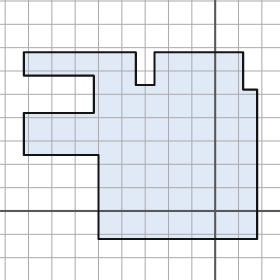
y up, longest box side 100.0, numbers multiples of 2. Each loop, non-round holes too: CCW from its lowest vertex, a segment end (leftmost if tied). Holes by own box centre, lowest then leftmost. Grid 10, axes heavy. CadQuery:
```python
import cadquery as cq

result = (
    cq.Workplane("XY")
    .moveTo(-50.0, -12.0)
    .lineTo(18.0, -12.0)
    .lineTo(18.0, 52.0)
    .lineTo(12.0, 52.0)
    .lineTo(12.0, 68.0)
    .lineTo(-26.0, 68.0)
    .lineTo(-26.0, 54.0)
    .lineTo(-34.0, 54.0)
    .lineTo(-34.0, 68.0)
    .lineTo(-82.0, 68.0)
    .lineTo(-82.0, 58.0)
    .lineTo(-52.0, 58.0)
    .lineTo(-52.0, 42.0)
    .lineTo(-82.0, 42.0)
    .lineTo(-82.0, 24.0)
    .lineTo(-50.0, 24.0)
    .close()
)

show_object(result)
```